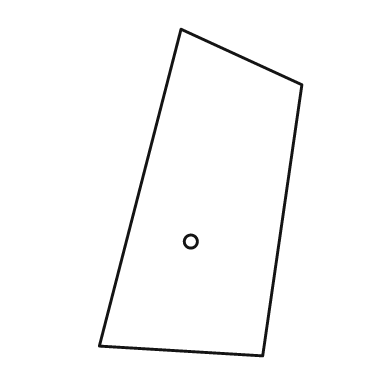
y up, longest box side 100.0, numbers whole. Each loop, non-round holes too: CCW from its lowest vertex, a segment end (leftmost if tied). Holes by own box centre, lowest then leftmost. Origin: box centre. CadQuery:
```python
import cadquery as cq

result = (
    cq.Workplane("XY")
    .moveTo(19.0, -50.0)
    .lineTo(31.0, 33.0)
    .lineTo(-6.0, 50.0)
    .lineTo(-31.0, -47.0)
    .close()
    .moveTo(-3.0, -15.0)
    .circle(2.0)
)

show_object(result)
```